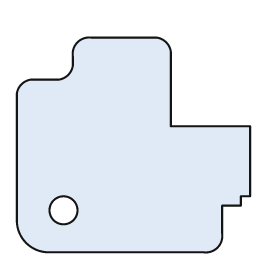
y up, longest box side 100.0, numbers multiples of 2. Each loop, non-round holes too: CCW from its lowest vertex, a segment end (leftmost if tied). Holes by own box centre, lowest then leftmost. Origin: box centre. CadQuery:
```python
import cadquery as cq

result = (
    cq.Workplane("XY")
    .moveTo(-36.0, -46.0)
    .lineTo(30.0, -46.0)
    .threePointArc((36.0, -44.0), (38.0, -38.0))
    .lineTo(38.0, -26.0)
    .lineTo(46.0, -26.0)
    .lineTo(46.0, -22.0)
    .lineTo(50.0, -22.0)
    .lineTo(50.0, 8.0)
    .lineTo(16.0, 8.0)
    .lineTo(16.0, 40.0)
    .threePointArc((14.0, 44.0), (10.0, 46.0))
    .lineTo(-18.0, 46.0)
    .threePointArc((-24.0, 44.0), (-26.0, 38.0))
    .lineTo(-26.0, 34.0)
    .threePointArc((-28.0, 30.0), (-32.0, 28.0))
    .lineTo(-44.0, 28.0)
    .threePointArc((-48.0, 26.0), (-50.0, 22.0))
    .lineTo(-50.0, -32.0)
    .threePointArc((-46.0, -42.0), (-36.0, -46.0))
    .close()
    .moveTo(-30.0, -28.0)
    .circle(6.0)
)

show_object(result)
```